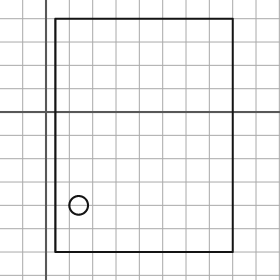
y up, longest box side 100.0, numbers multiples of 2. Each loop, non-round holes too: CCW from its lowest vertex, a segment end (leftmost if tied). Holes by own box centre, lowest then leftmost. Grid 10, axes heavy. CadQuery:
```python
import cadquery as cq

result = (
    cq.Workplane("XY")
    .moveTo(4.0, -60.0)
    .lineTo(80.0, -60.0)
    .lineTo(80.0, 40.0)
    .lineTo(4.0, 40.0)
    .close()
    .moveTo(14.0, -40.0)
    .circle(4.0)
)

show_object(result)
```